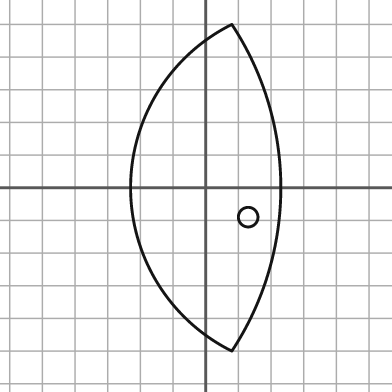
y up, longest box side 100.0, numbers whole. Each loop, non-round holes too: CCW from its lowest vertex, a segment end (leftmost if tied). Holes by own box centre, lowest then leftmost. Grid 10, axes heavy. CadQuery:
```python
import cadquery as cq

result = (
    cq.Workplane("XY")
    .moveTo(8.0, -50.0)
    .threePointArc((23.0, 0.0), (8.0, 50.0))
    .threePointArc((-23.0, 0.0), (8.0, -50.0))
    .close()
    .moveTo(13.0, -9.0)
    .circle(3.0)
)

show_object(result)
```